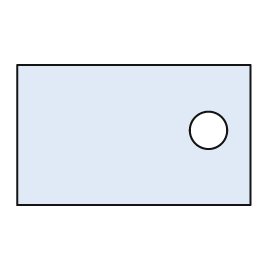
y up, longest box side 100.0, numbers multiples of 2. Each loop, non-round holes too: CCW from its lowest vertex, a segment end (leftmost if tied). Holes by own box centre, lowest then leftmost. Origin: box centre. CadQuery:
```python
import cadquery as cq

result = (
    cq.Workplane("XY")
    .moveTo(-50.0, -30.0)
    .lineTo(50.0, -30.0)
    .lineTo(50.0, 30.0)
    .lineTo(-50.0, 30.0)
    .close()
    .moveTo(32.0, 2.0)
    .circle(8.0)
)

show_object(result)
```